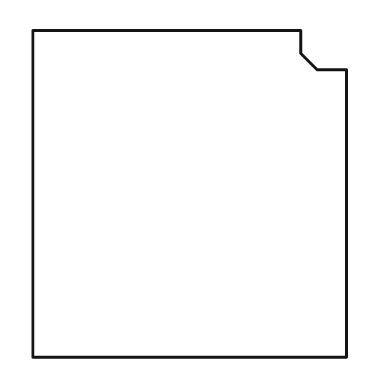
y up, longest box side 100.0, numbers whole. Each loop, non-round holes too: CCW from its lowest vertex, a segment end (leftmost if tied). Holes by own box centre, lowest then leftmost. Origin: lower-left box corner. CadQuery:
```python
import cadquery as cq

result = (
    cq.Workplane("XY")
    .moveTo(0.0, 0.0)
    .lineTo(96.0, 0.0)
    .lineTo(96.0, 88.0)
    .lineTo(87.0, 88.0)
    .lineTo(82.0, 93.0)
    .lineTo(82.0, 100.0)
    .lineTo(0.0, 100.0)
    .close()
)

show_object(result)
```